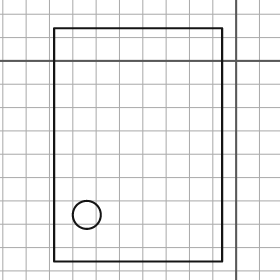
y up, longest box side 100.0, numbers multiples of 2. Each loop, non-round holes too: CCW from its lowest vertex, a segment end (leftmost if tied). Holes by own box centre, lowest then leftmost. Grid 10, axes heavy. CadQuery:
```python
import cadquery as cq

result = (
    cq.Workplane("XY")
    .moveTo(-78.0, -86.0)
    .lineTo(-6.0, -86.0)
    .lineTo(-6.0, 14.0)
    .lineTo(-78.0, 14.0)
    .close()
    .moveTo(-64.0, -66.0)
    .circle(6.0)
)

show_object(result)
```